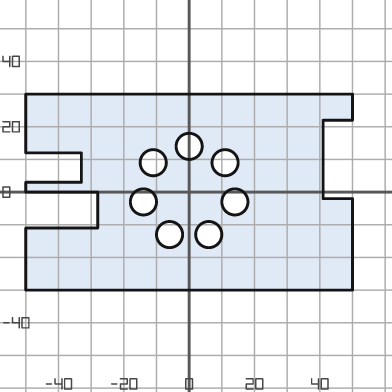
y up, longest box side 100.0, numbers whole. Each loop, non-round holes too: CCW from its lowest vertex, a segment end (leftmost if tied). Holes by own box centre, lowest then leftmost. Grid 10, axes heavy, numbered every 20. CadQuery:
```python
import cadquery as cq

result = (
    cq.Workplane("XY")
    .moveTo(-50.0, -30.0)
    .lineTo(50.0, -30.0)
    .lineTo(50.0, -2.0)
    .lineTo(41.0, -2.0)
    .lineTo(41.0, 22.0)
    .lineTo(50.0, 22.0)
    .lineTo(50.0, 30.0)
    .lineTo(-50.0, 30.0)
    .lineTo(-50.0, 12.0)
    .lineTo(-33.0, 12.0)
    .lineTo(-33.0, 3.0)
    .lineTo(-50.0, 3.0)
    .lineTo(-50.0, 0.0)
    .lineTo(-28.0, 0.0)
    .lineTo(-28.0, -11.0)
    .lineTo(-50.0, -11.0)
    .close()
    .moveTo(-6.0, -13.0)
    .circle(4.0)
    .moveTo(6.0, -13.0)
    .circle(4.0)
    .moveTo(-14.0, -3.0)
    .circle(4.0)
    .moveTo(14.0, -3.0)
    .circle(4.0)
    .moveTo(-11.0, 9.0)
    .circle(4.0)
    .moveTo(11.0, 9.0)
    .circle(4.0)
    .moveTo(0.0, 14.0)
    .circle(4.0)
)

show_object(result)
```